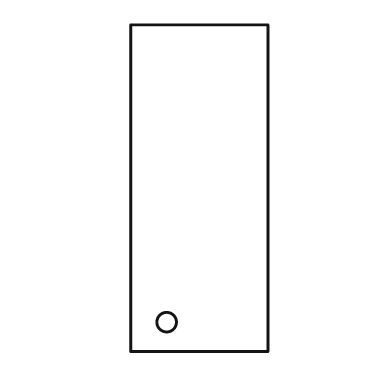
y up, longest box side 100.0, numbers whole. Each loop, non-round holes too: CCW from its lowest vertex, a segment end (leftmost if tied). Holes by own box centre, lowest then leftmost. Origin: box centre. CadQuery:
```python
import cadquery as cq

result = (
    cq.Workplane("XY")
    .moveTo(-21.0, -50.0)
    .lineTo(21.0, -50.0)
    .lineTo(21.0, 50.0)
    .lineTo(-21.0, 50.0)
    .close()
    .moveTo(-10.0, -41.0)
    .circle(3.0)
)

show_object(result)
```